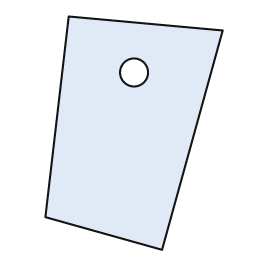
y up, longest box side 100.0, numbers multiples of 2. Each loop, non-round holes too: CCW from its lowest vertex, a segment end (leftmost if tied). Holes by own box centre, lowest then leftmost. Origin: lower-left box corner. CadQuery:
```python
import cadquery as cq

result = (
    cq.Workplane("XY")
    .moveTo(50.0, 0.0)
    .lineTo(76.0, 94.0)
    .lineTo(10.0, 100.0)
    .lineTo(0.0, 14.0)
    .close()
    .moveTo(38.0, 76.0)
    .circle(6.0)
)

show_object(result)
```